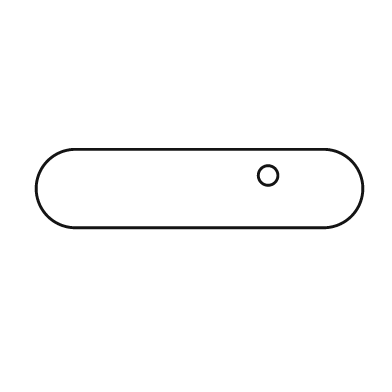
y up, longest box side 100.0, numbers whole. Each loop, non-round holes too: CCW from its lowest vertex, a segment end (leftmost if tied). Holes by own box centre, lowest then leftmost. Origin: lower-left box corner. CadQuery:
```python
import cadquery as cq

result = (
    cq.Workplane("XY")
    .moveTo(12.0, 0.0)
    .lineTo(88.0, 0.0)
    .threePointArc((100.0, 12.0), (88.0, 24.0))
    .lineTo(12.0, 24.0)
    .threePointArc((0.0, 12.0), (12.0, 0.0))
    .close()
    .moveTo(71.0, 16.0)
    .circle(3.0)
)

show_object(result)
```